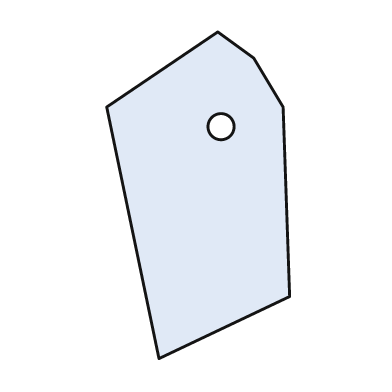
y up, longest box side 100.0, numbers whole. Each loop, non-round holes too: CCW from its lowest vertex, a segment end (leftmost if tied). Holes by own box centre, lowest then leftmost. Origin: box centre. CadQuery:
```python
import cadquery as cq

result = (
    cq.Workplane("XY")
    .moveTo(-12.0, -50.0)
    .lineTo(28.0, -31.0)
    .lineTo(26.0, 27.0)
    .lineTo(17.0, 42.0)
    .lineTo(6.0, 50.0)
    .lineTo(-28.0, 27.0)
    .close()
    .moveTo(7.0, 21.0)
    .circle(4.0)
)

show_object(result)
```